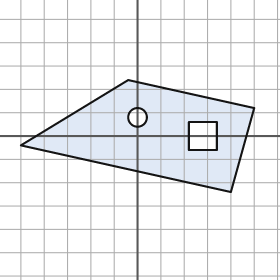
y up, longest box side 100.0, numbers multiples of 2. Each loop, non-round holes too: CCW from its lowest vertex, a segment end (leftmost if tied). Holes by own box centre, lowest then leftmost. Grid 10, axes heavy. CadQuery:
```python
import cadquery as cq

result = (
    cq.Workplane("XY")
    .moveTo(40.0, -24.0)
    .lineTo(50.0, 12.0)
    .lineTo(-4.0, 24.0)
    .lineTo(-50.0, -4.0)
    .close()
    .moveTo(22.0, -6.0)
    .lineTo(34.0, -6.0)
    .lineTo(34.0, 6.0)
    .lineTo(22.0, 6.0)
    .close()
    .moveTo(0.0, 8.0)
    .circle(4.0)
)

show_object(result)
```